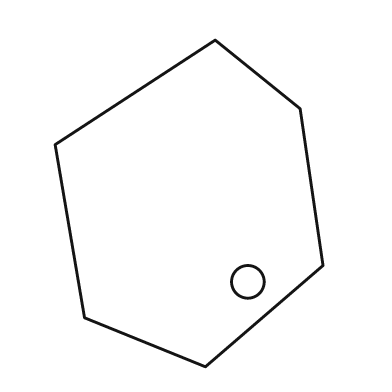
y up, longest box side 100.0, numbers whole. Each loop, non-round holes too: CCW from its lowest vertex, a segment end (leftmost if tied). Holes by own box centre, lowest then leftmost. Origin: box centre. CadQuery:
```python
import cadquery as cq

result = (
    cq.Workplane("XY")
    .moveTo(5.0, -50.0)
    .lineTo(41.0, -19.0)
    .lineTo(34.0, 29.0)
    .lineTo(8.0, 50.0)
    .lineTo(-41.0, 18.0)
    .lineTo(-32.0, -35.0)
    .close()
    .moveTo(18.0, -24.0)
    .circle(5.0)
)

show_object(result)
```